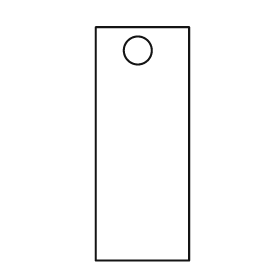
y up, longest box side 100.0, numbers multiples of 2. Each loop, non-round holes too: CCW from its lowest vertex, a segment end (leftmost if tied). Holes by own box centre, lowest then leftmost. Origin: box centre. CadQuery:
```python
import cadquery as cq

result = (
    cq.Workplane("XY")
    .moveTo(-20.0, -50.0)
    .lineTo(20.0, -50.0)
    .lineTo(20.0, 50.0)
    .lineTo(-20.0, 50.0)
    .close()
    .moveTo(-2.0, 40.0)
    .circle(6.0)
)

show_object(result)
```